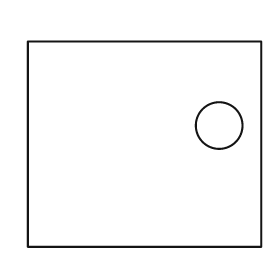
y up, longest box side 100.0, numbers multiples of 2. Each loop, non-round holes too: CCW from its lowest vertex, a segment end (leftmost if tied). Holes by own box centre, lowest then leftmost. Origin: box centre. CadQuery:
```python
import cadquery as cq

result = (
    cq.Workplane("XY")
    .moveTo(-50.0, -44.0)
    .lineTo(50.0, -44.0)
    .lineTo(50.0, 44.0)
    .lineTo(-50.0, 44.0)
    .close()
    .moveTo(32.0, 8.0)
    .circle(10.0)
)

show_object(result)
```